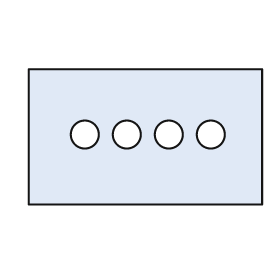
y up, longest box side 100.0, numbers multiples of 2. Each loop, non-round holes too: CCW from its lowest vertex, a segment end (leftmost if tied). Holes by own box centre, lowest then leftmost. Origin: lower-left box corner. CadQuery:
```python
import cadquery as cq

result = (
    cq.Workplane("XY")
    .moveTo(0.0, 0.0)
    .lineTo(100.0, 0.0)
    .lineTo(100.0, 58.0)
    .lineTo(0.0, 58.0)
    .close()
    .moveTo(24.0, 30.0)
    .circle(6.0)
    .moveTo(42.0, 30.0)
    .circle(6.0)
    .moveTo(60.0, 30.0)
    .circle(6.0)
    .moveTo(78.0, 30.0)
    .circle(6.0)
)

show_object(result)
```